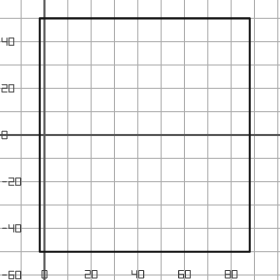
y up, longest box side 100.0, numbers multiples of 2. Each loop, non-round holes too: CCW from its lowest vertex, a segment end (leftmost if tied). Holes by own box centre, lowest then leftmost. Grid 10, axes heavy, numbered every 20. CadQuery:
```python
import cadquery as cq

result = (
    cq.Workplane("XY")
    .moveTo(-2.0, -50.0)
    .lineTo(88.0, -50.0)
    .lineTo(88.0, 50.0)
    .lineTo(-2.0, 50.0)
    .close()
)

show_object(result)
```